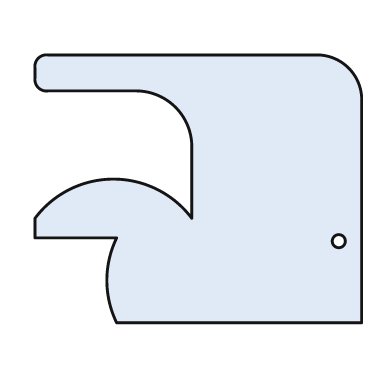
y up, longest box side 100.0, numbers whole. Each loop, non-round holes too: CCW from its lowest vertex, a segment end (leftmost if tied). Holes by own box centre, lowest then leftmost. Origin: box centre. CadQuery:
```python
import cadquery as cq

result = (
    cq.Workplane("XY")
    .moveTo(-25.0, -41.0)
    .lineTo(50.0, -41.0)
    .lineTo(50.0, 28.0)
    .threePointArc((46.0, 37.0), (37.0, 41.0))
    .lineTo(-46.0, 41.0)
    .threePointArc((-49.0, 40.0), (-50.0, 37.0))
    .lineTo(-50.0, 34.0)
    .threePointArc((-49.0, 31.0), (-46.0, 30.0))
    .lineTo(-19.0, 30.0)
    .threePointArc((-7.0, 25.0), (-2.0, 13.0))
    .lineTo(-2.0, -9.0)
    .threePointArc((-26.0, 3.0), (-50.0, -9.0))
    .lineTo(-50.0, -15.0)
    .lineTo(-25.0, -15.0)
    .threePointArc((-28.0, -28.0), (-25.0, -41.0))
    .close()
    .moveTo(43.0, -16.0)
    .circle(2.0)
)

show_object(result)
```